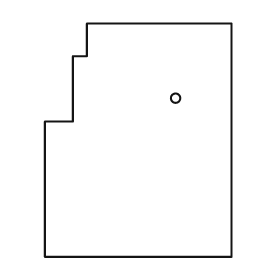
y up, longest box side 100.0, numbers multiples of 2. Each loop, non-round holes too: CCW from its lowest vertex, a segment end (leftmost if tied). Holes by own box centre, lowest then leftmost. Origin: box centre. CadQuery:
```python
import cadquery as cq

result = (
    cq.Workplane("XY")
    .moveTo(-40.0, -50.0)
    .lineTo(40.0, -50.0)
    .lineTo(40.0, 50.0)
    .lineTo(-22.0, 50.0)
    .lineTo(-22.0, 36.0)
    .lineTo(-28.0, 36.0)
    .lineTo(-28.0, 8.0)
    .lineTo(-40.0, 8.0)
    .close()
    .moveTo(16.0, 18.0)
    .circle(2.0)
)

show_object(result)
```